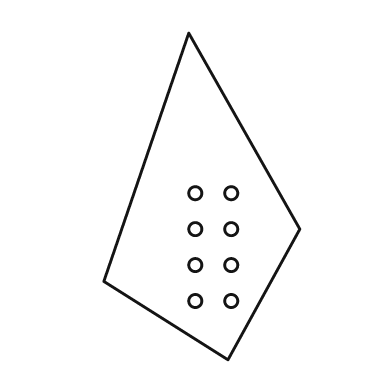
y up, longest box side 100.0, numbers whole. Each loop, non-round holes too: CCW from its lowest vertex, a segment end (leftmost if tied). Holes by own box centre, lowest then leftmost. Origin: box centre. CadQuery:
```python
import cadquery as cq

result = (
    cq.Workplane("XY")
    .moveTo(8.0, -50.0)
    .lineTo(30.0, -10.0)
    .lineTo(-4.0, 50.0)
    .lineTo(-30.0, -26.0)
    .close()
    .moveTo(-2.0, -32.0)
    .circle(2.0)
    .moveTo(9.0, -32.0)
    .circle(2.0)
    .moveTo(-2.0, -21.0)
    .circle(2.0)
    .moveTo(9.0, -21.0)
    .circle(2.0)
    .moveTo(-2.0, -10.0)
    .circle(2.0)
    .moveTo(9.0, -10.0)
    .circle(2.0)
    .moveTo(-2.0, 1.0)
    .circle(2.0)
    .moveTo(9.0, 1.0)
    .circle(2.0)
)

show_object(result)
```